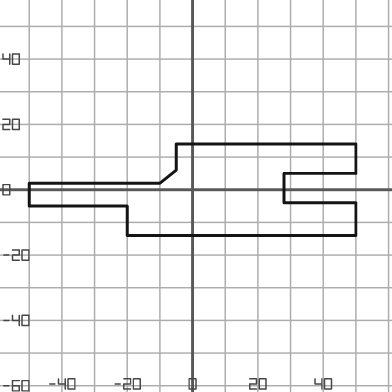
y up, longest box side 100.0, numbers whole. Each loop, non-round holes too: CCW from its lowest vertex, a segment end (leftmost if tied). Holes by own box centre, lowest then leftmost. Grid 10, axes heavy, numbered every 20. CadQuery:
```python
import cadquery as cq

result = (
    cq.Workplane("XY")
    .moveTo(-20.0, -14.0)
    .lineTo(50.0, -14.0)
    .lineTo(50.0, -4.0)
    .lineTo(28.0, -4.0)
    .lineTo(28.0, 5.0)
    .lineTo(50.0, 5.0)
    .lineTo(50.0, 14.0)
    .lineTo(-5.0, 14.0)
    .lineTo(-5.0, 6.0)
    .lineTo(-10.0, 2.0)
    .lineTo(-50.0, 2.0)
    .lineTo(-50.0, -5.0)
    .lineTo(-20.0, -5.0)
    .close()
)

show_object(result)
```